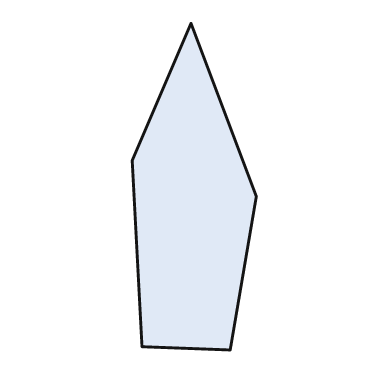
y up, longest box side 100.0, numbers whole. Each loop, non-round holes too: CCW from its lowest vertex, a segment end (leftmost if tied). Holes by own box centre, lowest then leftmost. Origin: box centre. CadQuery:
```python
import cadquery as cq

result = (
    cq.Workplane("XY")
    .moveTo(11.0, -50.0)
    .lineTo(19.0, -3.0)
    .lineTo(-1.0, 50.0)
    .lineTo(-19.0, 8.0)
    .lineTo(-16.0, -49.0)
    .close()
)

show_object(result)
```